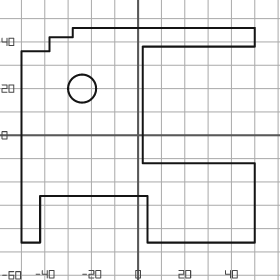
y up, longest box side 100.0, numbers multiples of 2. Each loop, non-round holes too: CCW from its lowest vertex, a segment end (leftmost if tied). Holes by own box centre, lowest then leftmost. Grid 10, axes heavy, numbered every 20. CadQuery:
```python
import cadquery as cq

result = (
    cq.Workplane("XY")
    .moveTo(-50.0, -46.0)
    .lineTo(-42.0, -46.0)
    .lineTo(-42.0, -26.0)
    .lineTo(4.0, -26.0)
    .lineTo(4.0, -46.0)
    .lineTo(50.0, -46.0)
    .lineTo(50.0, -12.0)
    .lineTo(2.0, -12.0)
    .lineTo(2.0, 38.0)
    .lineTo(50.0, 38.0)
    .lineTo(50.0, 46.0)
    .lineTo(-28.0, 46.0)
    .lineTo(-28.0, 42.0)
    .lineTo(-38.0, 42.0)
    .lineTo(-38.0, 36.0)
    .lineTo(-50.0, 36.0)
    .close()
    .moveTo(-24.0, 20.0)
    .circle(6.0)
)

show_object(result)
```